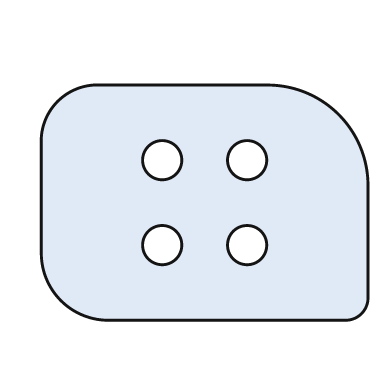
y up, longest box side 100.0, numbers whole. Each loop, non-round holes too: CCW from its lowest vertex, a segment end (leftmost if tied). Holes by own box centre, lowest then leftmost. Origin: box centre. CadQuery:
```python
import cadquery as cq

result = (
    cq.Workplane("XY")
    .moveTo(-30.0, -36.0)
    .lineTo(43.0, -36.0)
    .threePointArc((48.0, -34.0), (50.0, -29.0))
    .lineTo(50.0, 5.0)
    .threePointArc((41.0, 27.0), (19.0, 36.0))
    .lineTo(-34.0, 36.0)
    .threePointArc((-45.0, 31.0), (-50.0, 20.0))
    .lineTo(-50.0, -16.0)
    .threePointArc((-44.0, -30.0), (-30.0, -36.0))
    .close()
    .moveTo(-13.0, -13.0)
    .circle(6.0)
    .moveTo(13.0, -13.0)
    .circle(6.0)
    .moveTo(-13.0, 13.0)
    .circle(6.0)
    .moveTo(13.0, 13.0)
    .circle(6.0)
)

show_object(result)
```